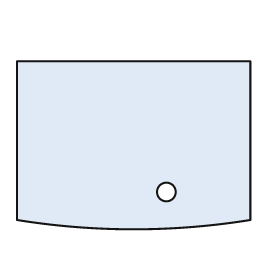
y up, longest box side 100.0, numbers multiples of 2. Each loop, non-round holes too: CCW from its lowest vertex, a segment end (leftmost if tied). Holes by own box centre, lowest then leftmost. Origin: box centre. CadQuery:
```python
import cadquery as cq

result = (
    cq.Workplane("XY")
    .moveTo(-50.0, -32.0)
    .threePointArc((0.0, -36.0), (50.0, -32.0))
    .lineTo(50.0, 36.0)
    .lineTo(-50.0, 36.0)
    .close()
    .moveTo(14.0, -20.0)
    .circle(4.0)
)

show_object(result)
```